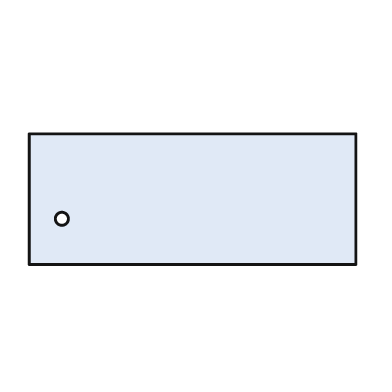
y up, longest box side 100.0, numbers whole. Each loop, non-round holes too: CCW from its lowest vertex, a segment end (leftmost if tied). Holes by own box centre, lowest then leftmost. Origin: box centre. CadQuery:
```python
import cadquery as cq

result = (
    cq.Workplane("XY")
    .moveTo(-50.0, -20.0)
    .lineTo(50.0, -20.0)
    .lineTo(50.0, 20.0)
    .lineTo(-50.0, 20.0)
    .close()
    .moveTo(-40.0, -6.0)
    .circle(2.0)
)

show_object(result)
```